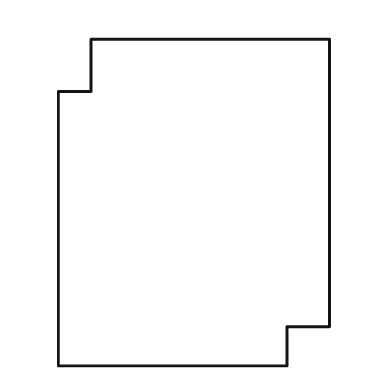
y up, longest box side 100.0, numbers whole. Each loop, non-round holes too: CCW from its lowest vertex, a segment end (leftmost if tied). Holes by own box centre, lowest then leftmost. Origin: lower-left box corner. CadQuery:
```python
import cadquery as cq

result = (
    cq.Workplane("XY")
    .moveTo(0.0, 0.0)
    .lineTo(70.0, 0.0)
    .lineTo(70.0, 12.0)
    .lineTo(83.0, 12.0)
    .lineTo(83.0, 100.0)
    .lineTo(10.0, 100.0)
    .lineTo(10.0, 84.0)
    .lineTo(0.0, 84.0)
    .close()
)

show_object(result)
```